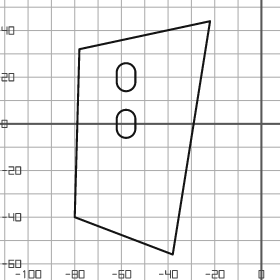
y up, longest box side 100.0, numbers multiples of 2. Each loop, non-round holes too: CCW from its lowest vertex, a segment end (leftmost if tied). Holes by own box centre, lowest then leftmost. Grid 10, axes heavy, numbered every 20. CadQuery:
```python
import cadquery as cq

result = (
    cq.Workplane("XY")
    .moveTo(-38.0, -56.0)
    .lineTo(-22.0, 44.0)
    .lineTo(-78.0, 32.0)
    .lineTo(-80.0, -40.0)
    .close()
    .moveTo(-62.0, -2.0)
    .threePointArc((-58.0, -6.0), (-54.0, -2.0))
    .lineTo(-54.0, 2.0)
    .threePointArc((-58.0, 6.0), (-62.0, 2.0))
    .close()
    .moveTo(-62.0, 18.0)
    .threePointArc((-58.0, 14.0), (-54.0, 18.0))
    .lineTo(-54.0, 22.0)
    .threePointArc((-58.0, 26.0), (-62.0, 22.0))
    .close()
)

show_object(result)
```